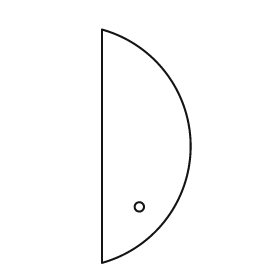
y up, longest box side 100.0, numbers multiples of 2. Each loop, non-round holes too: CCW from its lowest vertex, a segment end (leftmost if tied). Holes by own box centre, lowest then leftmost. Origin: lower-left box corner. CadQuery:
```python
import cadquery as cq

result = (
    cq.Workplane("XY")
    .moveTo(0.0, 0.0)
    .threePointArc((38.0, 50.0), (0.0, 100.0))
    .close()
    .moveTo(16.0, 24.0)
    .circle(2.0)
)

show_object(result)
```